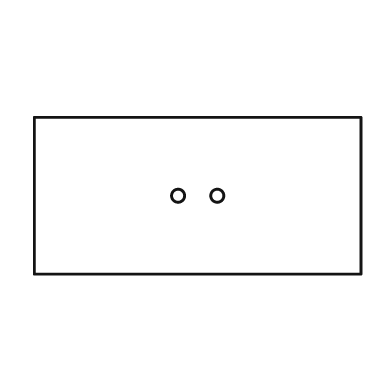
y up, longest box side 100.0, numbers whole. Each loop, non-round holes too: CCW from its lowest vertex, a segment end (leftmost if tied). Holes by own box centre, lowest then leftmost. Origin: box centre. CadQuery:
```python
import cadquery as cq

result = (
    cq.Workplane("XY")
    .moveTo(-50.0, -24.0)
    .lineTo(50.0, -24.0)
    .lineTo(50.0, 24.0)
    .lineTo(-50.0, 24.0)
    .close()
    .moveTo(-6.0, 0.0)
    .circle(2.0)
    .moveTo(6.0, 0.0)
    .circle(2.0)
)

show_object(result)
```